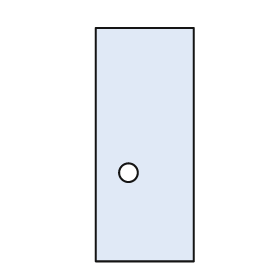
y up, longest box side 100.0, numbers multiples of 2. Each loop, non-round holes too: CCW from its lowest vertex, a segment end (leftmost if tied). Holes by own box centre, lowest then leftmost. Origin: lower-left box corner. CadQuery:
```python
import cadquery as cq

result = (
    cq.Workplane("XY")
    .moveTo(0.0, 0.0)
    .lineTo(42.0, 0.0)
    .lineTo(42.0, 100.0)
    .lineTo(0.0, 100.0)
    .close()
    .moveTo(14.0, 38.0)
    .circle(4.0)
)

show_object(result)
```